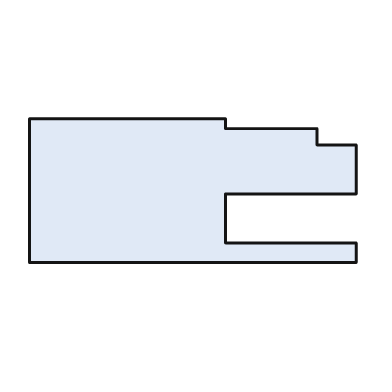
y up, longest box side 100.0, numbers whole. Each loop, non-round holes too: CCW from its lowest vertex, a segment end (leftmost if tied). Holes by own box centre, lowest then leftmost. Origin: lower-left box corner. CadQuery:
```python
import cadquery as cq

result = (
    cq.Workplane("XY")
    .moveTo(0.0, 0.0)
    .lineTo(100.0, 0.0)
    .lineTo(100.0, 6.0)
    .lineTo(60.0, 6.0)
    .lineTo(60.0, 21.0)
    .lineTo(100.0, 21.0)
    .lineTo(100.0, 36.0)
    .lineTo(88.0, 36.0)
    .lineTo(88.0, 41.0)
    .lineTo(60.0, 41.0)
    .lineTo(60.0, 44.0)
    .lineTo(0.0, 44.0)
    .close()
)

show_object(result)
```